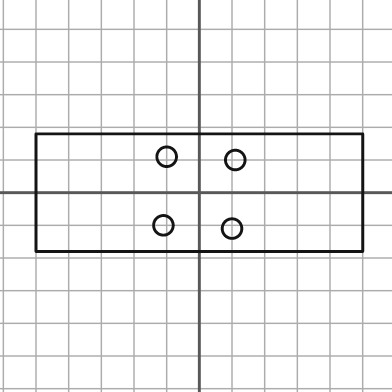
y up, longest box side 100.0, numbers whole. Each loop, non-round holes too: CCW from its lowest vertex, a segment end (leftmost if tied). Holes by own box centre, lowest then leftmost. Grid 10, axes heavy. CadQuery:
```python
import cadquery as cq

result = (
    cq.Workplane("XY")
    .moveTo(-50.0, -18.0)
    .lineTo(50.0, -18.0)
    .lineTo(50.0, 18.0)
    .lineTo(-50.0, 18.0)
    .close()
    .moveTo(10.0, -11.0)
    .circle(3.0)
    .moveTo(-11.0, -10.0)
    .circle(3.0)
    .moveTo(11.0, 10.0)
    .circle(3.0)
    .moveTo(-10.0, 11.0)
    .circle(3.0)
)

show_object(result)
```